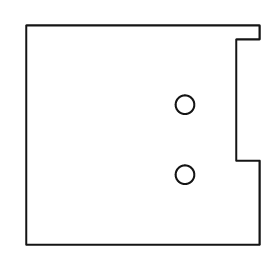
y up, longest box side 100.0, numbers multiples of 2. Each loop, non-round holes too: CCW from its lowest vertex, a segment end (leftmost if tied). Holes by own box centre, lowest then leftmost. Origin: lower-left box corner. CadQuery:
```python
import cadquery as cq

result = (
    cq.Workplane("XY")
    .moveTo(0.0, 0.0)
    .lineTo(100.0, 0.0)
    .lineTo(100.0, 36.0)
    .lineTo(90.0, 36.0)
    .lineTo(90.0, 88.0)
    .lineTo(100.0, 88.0)
    .lineTo(100.0, 94.0)
    .lineTo(0.0, 94.0)
    .close()
    .moveTo(68.0, 30.0)
    .circle(4.0)
    .moveTo(68.0, 60.0)
    .circle(4.0)
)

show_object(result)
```